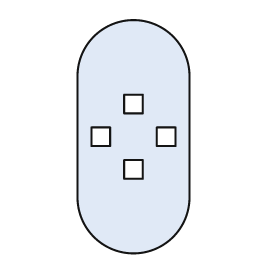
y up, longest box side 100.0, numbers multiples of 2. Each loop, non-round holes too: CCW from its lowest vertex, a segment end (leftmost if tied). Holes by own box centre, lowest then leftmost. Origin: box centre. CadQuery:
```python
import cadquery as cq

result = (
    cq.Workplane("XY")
    .moveTo(-24.0, -26.0)
    .threePointArc((0.0, -50.0), (24.0, -26.0))
    .lineTo(24.0, 26.0)
    .threePointArc((0.0, 50.0), (-24.0, 26.0))
    .close()
    .moveTo(-4.0, -18.0)
    .lineTo(4.0, -18.0)
    .lineTo(4.0, -10.0)
    .lineTo(-4.0, -10.0)
    .close()
    .moveTo(-18.0, -4.0)
    .lineTo(-10.0, -4.0)
    .lineTo(-10.0, 4.0)
    .lineTo(-18.0, 4.0)
    .close()
    .moveTo(10.0, -4.0)
    .lineTo(18.0, -4.0)
    .lineTo(18.0, 4.0)
    .lineTo(10.0, 4.0)
    .close()
    .moveTo(-4.0, 10.0)
    .lineTo(4.0, 10.0)
    .lineTo(4.0, 18.0)
    .lineTo(-4.0, 18.0)
    .close()
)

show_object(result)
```